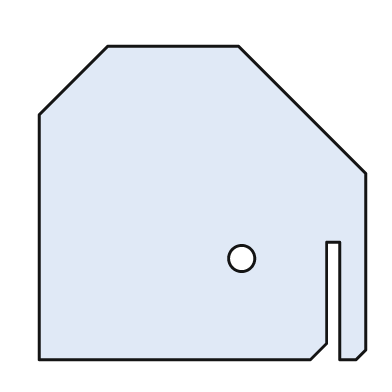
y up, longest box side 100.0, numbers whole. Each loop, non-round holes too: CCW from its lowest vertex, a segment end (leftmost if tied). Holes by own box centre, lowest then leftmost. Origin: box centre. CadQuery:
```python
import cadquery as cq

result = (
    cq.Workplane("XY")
    .moveTo(-50.0, -48.0)
    .lineTo(33.0, -48.0)
    .lineTo(38.0, -43.0)
    .lineTo(38.0, -12.0)
    .lineTo(42.0, -12.0)
    .lineTo(42.0, -48.0)
    .lineTo(47.0, -48.0)
    .lineTo(50.0, -45.0)
    .lineTo(50.0, 9.0)
    .lineTo(11.0, 48.0)
    .lineTo(-29.0, 48.0)
    .lineTo(-50.0, 27.0)
    .close()
    .moveTo(12.0, -17.0)
    .circle(4.0)
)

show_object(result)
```